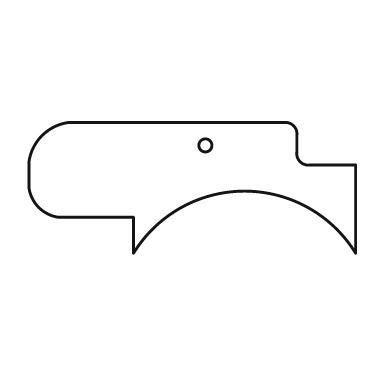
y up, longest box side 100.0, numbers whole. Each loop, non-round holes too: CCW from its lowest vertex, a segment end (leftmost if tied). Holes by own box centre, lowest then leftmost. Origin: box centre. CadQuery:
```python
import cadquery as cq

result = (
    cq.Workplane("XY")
    .moveTo(-18.0, -20.0)
    .threePointArc((16.0, -1.0), (50.0, -20.0))
    .lineTo(50.0, 7.0)
    .lineTo(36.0, 7.0)
    .threePointArc((33.0, 8.0), (32.0, 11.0))
    .lineTo(32.0, 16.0)
    .threePointArc((31.0, 19.0), (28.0, 20.0))
    .lineTo(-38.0, 20.0)
    .threePointArc((-46.0, 16.0), (-50.0, 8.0))
    .lineTo(-50.0, 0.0)
    .threePointArc((-47.0, -6.0), (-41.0, -9.0))
    .lineTo(-18.0, -9.0)
    .close()
    .moveTo(4.0, 13.0)
    .circle(2.0)
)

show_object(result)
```